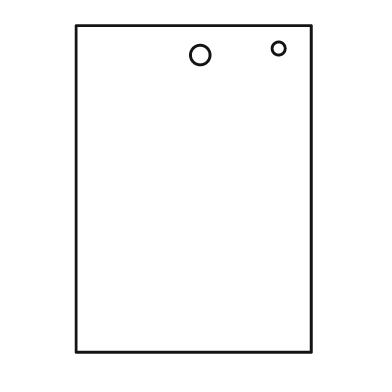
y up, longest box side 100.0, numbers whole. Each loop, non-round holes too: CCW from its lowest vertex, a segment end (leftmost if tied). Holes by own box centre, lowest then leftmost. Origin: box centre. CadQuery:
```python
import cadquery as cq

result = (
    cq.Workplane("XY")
    .moveTo(-36.0, -50.0)
    .lineTo(36.0, -50.0)
    .lineTo(36.0, 50.0)
    .lineTo(-36.0, 50.0)
    .close()
    .moveTo(2.0, 41.0)
    .circle(3.0)
    .moveTo(26.0, 43.0)
    .circle(2.0)
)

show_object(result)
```